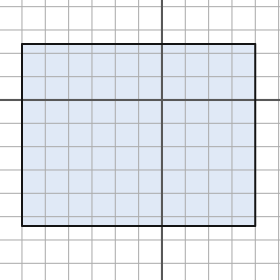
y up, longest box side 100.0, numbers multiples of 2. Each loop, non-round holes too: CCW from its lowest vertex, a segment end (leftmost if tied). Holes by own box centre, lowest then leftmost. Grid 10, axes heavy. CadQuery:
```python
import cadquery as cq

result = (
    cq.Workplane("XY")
    .moveTo(-60.0, -54.0)
    .lineTo(40.0, -54.0)
    .lineTo(40.0, 24.0)
    .lineTo(-60.0, 24.0)
    .close()
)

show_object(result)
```